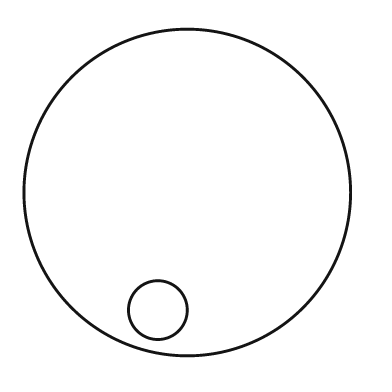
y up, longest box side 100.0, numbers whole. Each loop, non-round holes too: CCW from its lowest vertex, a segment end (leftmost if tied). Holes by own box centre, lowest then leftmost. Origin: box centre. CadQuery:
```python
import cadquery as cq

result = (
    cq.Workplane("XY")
    .moveTo(0.0, 0.0)
    .circle(50.0)
    .moveTo(-9.0, -36.0)
    .circle(9.0)
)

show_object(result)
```